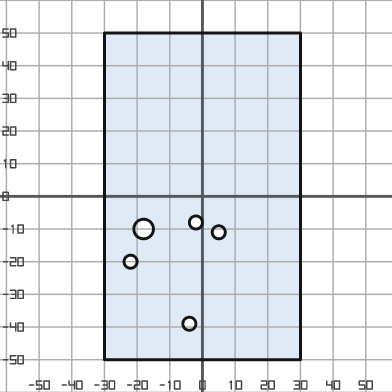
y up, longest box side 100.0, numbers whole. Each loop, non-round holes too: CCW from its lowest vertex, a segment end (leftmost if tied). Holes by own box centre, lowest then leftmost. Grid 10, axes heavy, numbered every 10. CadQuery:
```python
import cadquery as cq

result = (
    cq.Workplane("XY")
    .moveTo(-30.0, -50.0)
    .lineTo(30.0, -50.0)
    .lineTo(30.0, 50.0)
    .lineTo(-30.0, 50.0)
    .close()
    .moveTo(-4.0, -39.0)
    .circle(2.0)
    .moveTo(-22.0, -20.0)
    .circle(2.0)
    .moveTo(5.0, -11.0)
    .circle(2.0)
    .moveTo(-18.0, -10.0)
    .circle(3.0)
    .moveTo(-2.0, -8.0)
    .circle(2.0)
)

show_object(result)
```